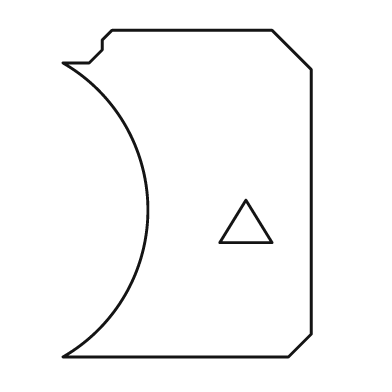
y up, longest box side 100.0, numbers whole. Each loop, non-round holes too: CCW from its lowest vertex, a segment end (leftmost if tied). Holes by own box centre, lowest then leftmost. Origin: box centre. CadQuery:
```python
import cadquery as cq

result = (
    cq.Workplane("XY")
    .moveTo(-38.0, -50.0)
    .lineTo(31.0, -50.0)
    .lineTo(38.0, -43.0)
    .lineTo(38.0, 38.0)
    .lineTo(26.0, 50.0)
    .lineTo(-23.0, 50.0)
    .lineTo(-26.0, 47.0)
    .lineTo(-26.0, 44.0)
    .lineTo(-30.0, 40.0)
    .lineTo(-38.0, 40.0)
    .threePointArc((-12.0, -5.0), (-38.0, -50.0))
    .close()
    .moveTo(10.0, -15.0)
    .lineTo(26.0, -15.0)
    .lineTo(18.0, -2.0)
    .close()
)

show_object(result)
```